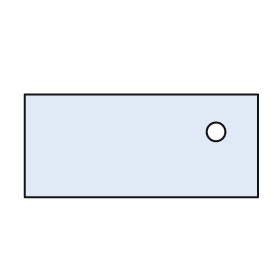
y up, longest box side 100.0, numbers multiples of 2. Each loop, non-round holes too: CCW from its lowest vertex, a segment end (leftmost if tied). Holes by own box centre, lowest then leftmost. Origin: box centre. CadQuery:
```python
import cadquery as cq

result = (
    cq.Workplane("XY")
    .moveTo(-50.0, -22.0)
    .lineTo(50.0, -22.0)
    .lineTo(50.0, 22.0)
    .lineTo(-50.0, 22.0)
    .close()
    .moveTo(32.0, 6.0)
    .circle(4.0)
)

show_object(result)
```